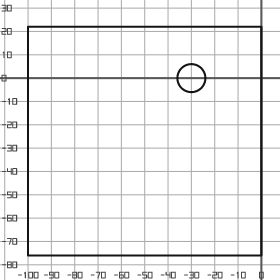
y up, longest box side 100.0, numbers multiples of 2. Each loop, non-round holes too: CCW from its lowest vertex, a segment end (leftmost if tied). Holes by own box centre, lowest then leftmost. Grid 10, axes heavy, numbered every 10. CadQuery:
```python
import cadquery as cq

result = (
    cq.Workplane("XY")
    .moveTo(-100.0, -76.0)
    .lineTo(0.0, -76.0)
    .lineTo(0.0, 22.0)
    .lineTo(-100.0, 22.0)
    .close()
    .moveTo(-30.0, 0.0)
    .circle(6.0)
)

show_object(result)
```